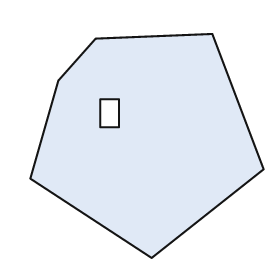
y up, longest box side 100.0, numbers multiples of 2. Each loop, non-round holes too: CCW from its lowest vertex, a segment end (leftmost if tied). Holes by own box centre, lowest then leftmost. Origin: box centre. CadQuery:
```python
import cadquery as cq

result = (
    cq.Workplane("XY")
    .moveTo(2.0, -48.0)
    .lineTo(50.0, -10.0)
    .lineTo(28.0, 48.0)
    .lineTo(-22.0, 46.0)
    .lineTo(-38.0, 28.0)
    .lineTo(-50.0, -14.0)
    .close()
    .moveTo(-20.0, 8.0)
    .lineTo(-12.0, 8.0)
    .lineTo(-12.0, 20.0)
    .lineTo(-20.0, 20.0)
    .close()
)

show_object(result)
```